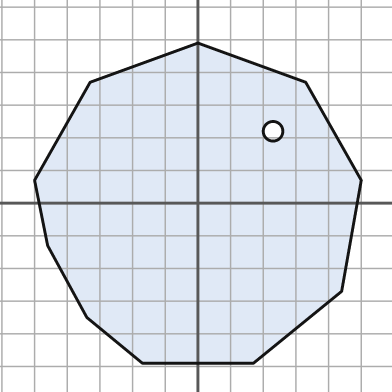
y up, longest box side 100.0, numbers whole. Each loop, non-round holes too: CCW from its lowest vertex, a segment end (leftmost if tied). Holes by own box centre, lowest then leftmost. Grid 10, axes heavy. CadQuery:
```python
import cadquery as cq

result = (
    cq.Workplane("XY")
    .moveTo(-17.0, -49.0)
    .lineTo(17.0, -49.0)
    .lineTo(44.0, -27.0)
    .lineTo(50.0, 7.0)
    .lineTo(33.0, 37.0)
    .lineTo(0.0, 49.0)
    .lineTo(-33.0, 37.0)
    .lineTo(-50.0, 7.0)
    .lineTo(-46.0, -13.0)
    .lineTo(-34.0, -35.0)
    .close()
    .moveTo(23.0, 22.0)
    .circle(3.0)
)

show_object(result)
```